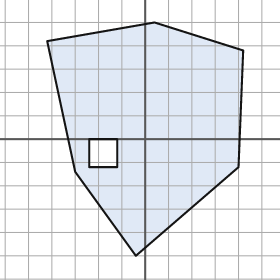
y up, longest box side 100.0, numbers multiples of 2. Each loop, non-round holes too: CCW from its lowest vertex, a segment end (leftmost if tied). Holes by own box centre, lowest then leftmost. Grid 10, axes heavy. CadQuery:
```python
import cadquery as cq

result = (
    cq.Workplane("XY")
    .moveTo(-4.0, -50.0)
    .lineTo(40.0, -12.0)
    .lineTo(42.0, 38.0)
    .lineTo(4.0, 50.0)
    .lineTo(-42.0, 42.0)
    .lineTo(-30.0, -14.0)
    .close()
    .moveTo(-24.0, -12.0)
    .lineTo(-12.0, -12.0)
    .lineTo(-12.0, 0.0)
    .lineTo(-24.0, 0.0)
    .close()
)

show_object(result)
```